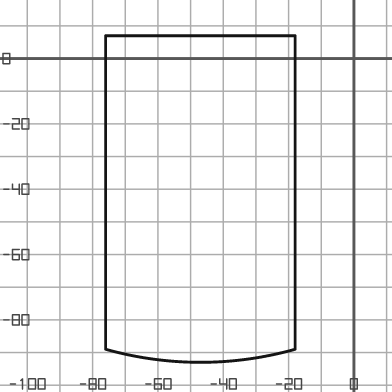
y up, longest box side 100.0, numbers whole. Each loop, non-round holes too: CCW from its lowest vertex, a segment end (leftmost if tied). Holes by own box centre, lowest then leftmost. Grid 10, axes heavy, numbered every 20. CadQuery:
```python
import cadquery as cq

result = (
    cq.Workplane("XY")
    .moveTo(-76.0, -89.0)
    .threePointArc((-47.0, -93.0), (-18.0, -89.0))
    .lineTo(-18.0, 7.0)
    .lineTo(-76.0, 7.0)
    .close()
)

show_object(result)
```